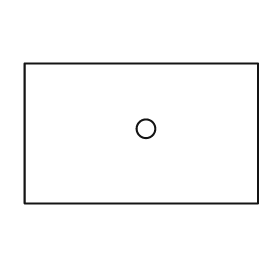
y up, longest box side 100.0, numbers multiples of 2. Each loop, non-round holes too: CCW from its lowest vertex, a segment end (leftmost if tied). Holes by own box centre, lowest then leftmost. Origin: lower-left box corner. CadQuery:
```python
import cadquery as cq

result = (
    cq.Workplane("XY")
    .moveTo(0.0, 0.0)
    .lineTo(100.0, 0.0)
    .lineTo(100.0, 60.0)
    .lineTo(0.0, 60.0)
    .close()
    .moveTo(52.0, 32.0)
    .circle(4.0)
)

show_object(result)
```